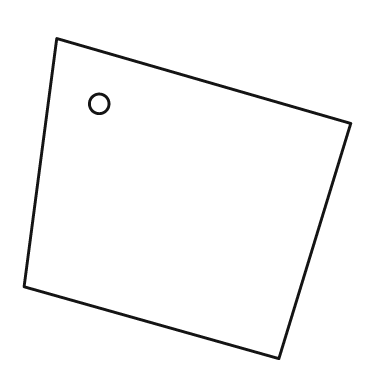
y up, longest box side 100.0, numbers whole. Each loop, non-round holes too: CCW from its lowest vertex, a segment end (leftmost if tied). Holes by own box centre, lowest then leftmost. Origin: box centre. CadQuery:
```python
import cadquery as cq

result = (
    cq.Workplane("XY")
    .moveTo(28.0, -49.0)
    .lineTo(50.0, 23.0)
    .lineTo(-40.0, 49.0)
    .lineTo(-50.0, -27.0)
    .close()
    .moveTo(-27.0, 29.0)
    .circle(3.0)
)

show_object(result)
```